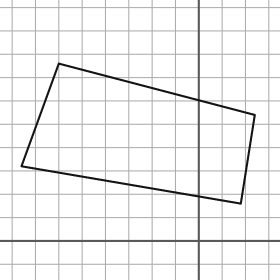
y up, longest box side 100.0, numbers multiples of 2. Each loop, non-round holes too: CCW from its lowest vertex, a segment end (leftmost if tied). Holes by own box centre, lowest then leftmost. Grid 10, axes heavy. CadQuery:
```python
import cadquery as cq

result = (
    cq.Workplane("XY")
    .moveTo(18.0, 16.0)
    .lineTo(24.0, 54.0)
    .lineTo(-60.0, 76.0)
    .lineTo(-76.0, 32.0)
    .close()
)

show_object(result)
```